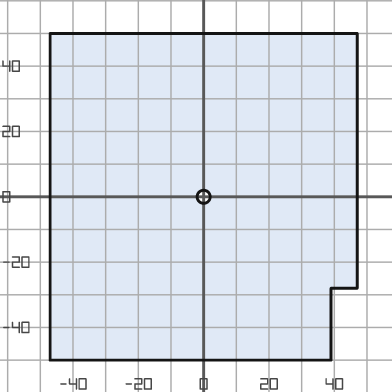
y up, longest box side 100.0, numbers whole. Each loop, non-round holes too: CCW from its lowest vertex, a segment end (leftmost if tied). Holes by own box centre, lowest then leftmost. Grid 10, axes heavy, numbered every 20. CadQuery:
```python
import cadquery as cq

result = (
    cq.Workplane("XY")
    .moveTo(-47.0, -50.0)
    .lineTo(39.0, -50.0)
    .lineTo(39.0, -28.0)
    .lineTo(47.0, -28.0)
    .lineTo(47.0, 50.0)
    .lineTo(-47.0, 50.0)
    .close()
    .moveTo(0.0, 0.0)
    .circle(2.0)
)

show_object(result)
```